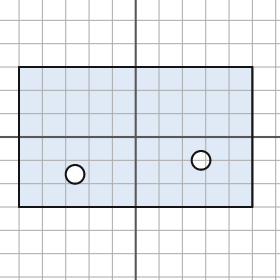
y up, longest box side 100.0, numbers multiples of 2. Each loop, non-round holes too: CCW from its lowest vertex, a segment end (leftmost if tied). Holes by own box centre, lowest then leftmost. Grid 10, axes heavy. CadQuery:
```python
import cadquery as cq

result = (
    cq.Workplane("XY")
    .moveTo(-50.0, -30.0)
    .lineTo(50.0, -30.0)
    .lineTo(50.0, 30.0)
    .lineTo(-50.0, 30.0)
    .close()
    .moveTo(-26.0, -16.0)
    .circle(4.0)
    .moveTo(28.0, -10.0)
    .circle(4.0)
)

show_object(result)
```